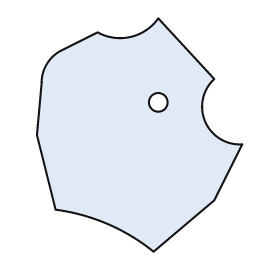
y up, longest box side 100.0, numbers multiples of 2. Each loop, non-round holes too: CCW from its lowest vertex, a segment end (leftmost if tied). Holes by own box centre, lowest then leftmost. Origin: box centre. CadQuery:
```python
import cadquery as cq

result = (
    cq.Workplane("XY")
    .moveTo(6.0, -50.0)
    .lineTo(32.0, -28.0)
    .lineTo(44.0, -4.0)
    .threePointArc((28.0, 6.0), (32.0, 24.0))
    .lineTo(8.0, 50.0)
    .threePointArc((-4.0, 42.0), (-18.0, 44.0))
    .lineTo(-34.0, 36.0)
    .threePointArc((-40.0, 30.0), (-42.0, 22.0))
    .lineTo(-44.0, 0.0)
    .lineTo(-36.0, -32.0)
    .threePointArc((-14.0, -38.0), (6.0, -50.0))
    .close()
    .moveTo(8.0, 14.0)
    .circle(4.0)
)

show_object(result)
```